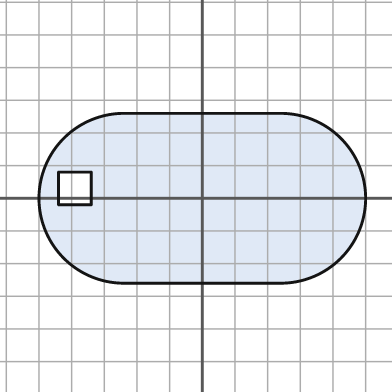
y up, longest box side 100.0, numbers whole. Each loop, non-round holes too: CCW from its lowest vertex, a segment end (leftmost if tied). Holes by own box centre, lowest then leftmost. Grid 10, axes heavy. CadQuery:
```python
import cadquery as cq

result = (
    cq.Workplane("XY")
    .moveTo(-24.0, -26.0)
    .lineTo(24.0, -26.0)
    .threePointArc((50.0, 0.0), (24.0, 26.0))
    .lineTo(-24.0, 26.0)
    .threePointArc((-50.0, 0.0), (-24.0, -26.0))
    .close()
    .moveTo(-44.0, -2.0)
    .lineTo(-34.0, -2.0)
    .lineTo(-34.0, 8.0)
    .lineTo(-44.0, 8.0)
    .close()
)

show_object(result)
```